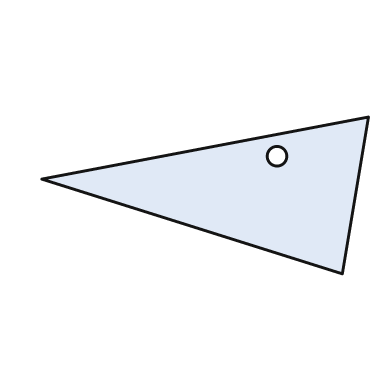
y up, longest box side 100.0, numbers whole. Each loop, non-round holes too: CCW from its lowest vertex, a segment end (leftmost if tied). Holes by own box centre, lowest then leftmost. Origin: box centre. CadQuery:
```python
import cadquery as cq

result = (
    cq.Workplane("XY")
    .moveTo(42.0, -24.0)
    .lineTo(50.0, 24.0)
    .lineTo(-50.0, 5.0)
    .close()
    .moveTo(22.0, 12.0)
    .circle(3.0)
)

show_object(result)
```